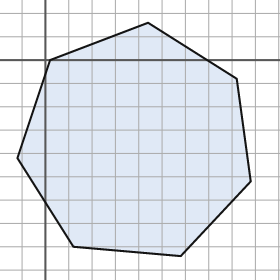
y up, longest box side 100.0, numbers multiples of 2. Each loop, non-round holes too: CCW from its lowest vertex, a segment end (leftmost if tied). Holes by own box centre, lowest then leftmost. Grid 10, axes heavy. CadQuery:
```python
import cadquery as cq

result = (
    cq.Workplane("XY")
    .moveTo(58.0, -84.0)
    .lineTo(88.0, -52.0)
    .lineTo(82.0, -8.0)
    .lineTo(44.0, 16.0)
    .lineTo(2.0, 0.0)
    .lineTo(-12.0, -42.0)
    .lineTo(12.0, -80.0)
    .close()
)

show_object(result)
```